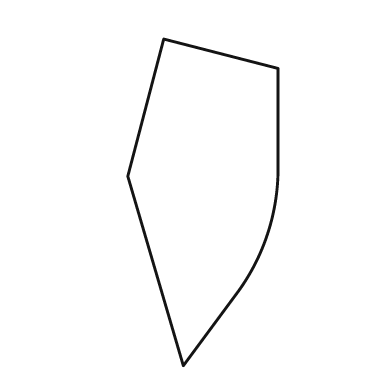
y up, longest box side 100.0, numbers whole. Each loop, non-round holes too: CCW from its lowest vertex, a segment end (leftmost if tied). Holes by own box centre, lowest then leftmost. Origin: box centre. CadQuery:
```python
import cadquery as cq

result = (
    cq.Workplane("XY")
    .moveTo(-6.0, -50.0)
    .lineTo(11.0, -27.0)
    .threePointArc((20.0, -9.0), (23.0, 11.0))
    .lineTo(23.0, 41.0)
    .lineTo(-12.0, 50.0)
    .lineTo(-23.0, 8.0)
    .close()
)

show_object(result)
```